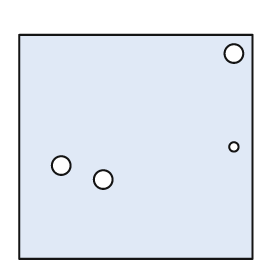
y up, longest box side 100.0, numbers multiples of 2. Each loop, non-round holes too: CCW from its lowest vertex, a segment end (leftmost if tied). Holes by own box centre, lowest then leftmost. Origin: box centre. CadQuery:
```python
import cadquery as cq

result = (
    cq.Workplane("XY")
    .moveTo(-50.0, -48.0)
    .lineTo(50.0, -48.0)
    .lineTo(50.0, 48.0)
    .lineTo(-50.0, 48.0)
    .close()
    .moveTo(-14.0, -14.0)
    .circle(4.0)
    .moveTo(-32.0, -8.0)
    .circle(4.0)
    .moveTo(42.0, 0.0)
    .circle(2.0)
    .moveTo(42.0, 40.0)
    .circle(4.0)
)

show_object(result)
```